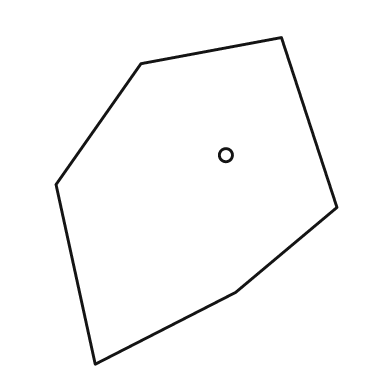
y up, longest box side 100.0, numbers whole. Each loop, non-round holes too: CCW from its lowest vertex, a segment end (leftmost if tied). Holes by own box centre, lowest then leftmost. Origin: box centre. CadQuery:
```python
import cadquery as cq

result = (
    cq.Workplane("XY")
    .moveTo(-31.0, -50.0)
    .lineTo(12.0, -28.0)
    .lineTo(43.0, -2.0)
    .lineTo(26.0, 50.0)
    .lineTo(-17.0, 42.0)
    .lineTo(-43.0, 5.0)
    .close()
    .moveTo(9.0, 14.0)
    .circle(2.0)
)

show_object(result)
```